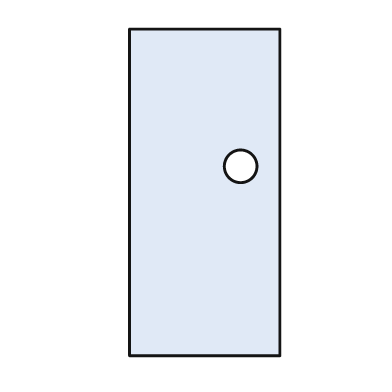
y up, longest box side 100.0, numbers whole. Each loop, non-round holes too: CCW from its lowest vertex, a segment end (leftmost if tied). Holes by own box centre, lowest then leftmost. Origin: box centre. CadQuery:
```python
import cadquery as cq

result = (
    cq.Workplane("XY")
    .moveTo(-23.0, -50.0)
    .lineTo(23.0, -50.0)
    .lineTo(23.0, 50.0)
    .lineTo(-23.0, 50.0)
    .close()
    .moveTo(11.0, 8.0)
    .circle(5.0)
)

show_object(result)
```